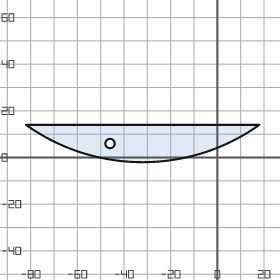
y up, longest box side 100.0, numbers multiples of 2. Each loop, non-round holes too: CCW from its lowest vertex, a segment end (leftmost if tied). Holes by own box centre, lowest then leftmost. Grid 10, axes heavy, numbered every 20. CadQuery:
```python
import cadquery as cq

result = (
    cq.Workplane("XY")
    .moveTo(-82.0, 14.0)
    .threePointArc((-32.0, -2.0), (18.0, 14.0))
    .close()
    .moveTo(-46.0, 6.0)
    .circle(2.0)
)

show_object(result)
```